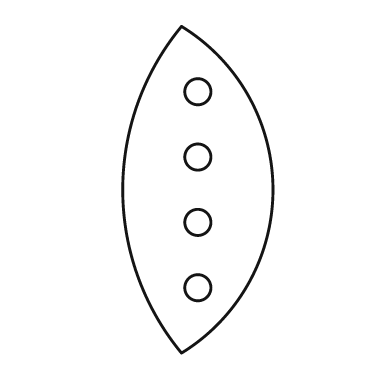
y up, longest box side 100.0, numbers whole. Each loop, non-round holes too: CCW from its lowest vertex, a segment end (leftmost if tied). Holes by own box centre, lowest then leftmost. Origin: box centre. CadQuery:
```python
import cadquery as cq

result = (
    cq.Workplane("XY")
    .moveTo(-5.0, -50.0)
    .threePointArc((23.0, 0.0), (-5.0, 50.0))
    .threePointArc((-23.0, 0.0), (-5.0, -50.0))
    .close()
    .moveTo(0.0, -30.0)
    .circle(4.0)
    .moveTo(0.0, -10.0)
    .circle(4.0)
    .moveTo(0.0, 10.0)
    .circle(4.0)
    .moveTo(0.0, 30.0)
    .circle(4.0)
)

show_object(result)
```